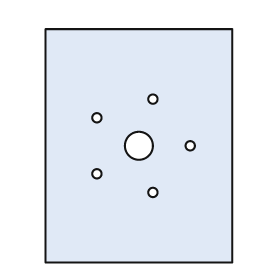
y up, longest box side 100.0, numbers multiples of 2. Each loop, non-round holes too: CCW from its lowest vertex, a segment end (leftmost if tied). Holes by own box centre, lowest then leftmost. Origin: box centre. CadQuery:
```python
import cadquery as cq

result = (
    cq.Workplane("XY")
    .moveTo(-40.0, -50.0)
    .lineTo(40.0, -50.0)
    .lineTo(40.0, 50.0)
    .lineTo(-40.0, 50.0)
    .close()
    .moveTo(6.0, -20.0)
    .circle(2.0)
    .moveTo(-18.0, -12.0)
    .circle(2.0)
    .moveTo(0.0, 0.0)
    .circle(6.0)
    .moveTo(22.0, 0.0)
    .circle(2.0)
    .moveTo(-18.0, 12.0)
    .circle(2.0)
    .moveTo(6.0, 20.0)
    .circle(2.0)
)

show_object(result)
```